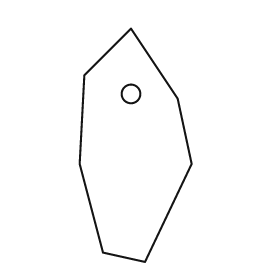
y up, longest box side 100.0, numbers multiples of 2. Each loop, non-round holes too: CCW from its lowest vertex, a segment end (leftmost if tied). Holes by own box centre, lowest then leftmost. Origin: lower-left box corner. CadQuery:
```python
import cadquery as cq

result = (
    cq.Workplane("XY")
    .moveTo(28.0, 0.0)
    .lineTo(48.0, 42.0)
    .lineTo(42.0, 70.0)
    .lineTo(22.0, 100.0)
    .lineTo(2.0, 80.0)
    .lineTo(0.0, 42.0)
    .lineTo(10.0, 4.0)
    .close()
    .moveTo(22.0, 72.0)
    .circle(4.0)
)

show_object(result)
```